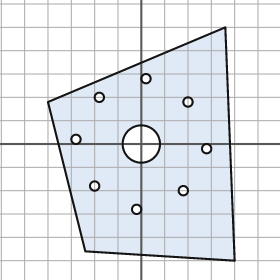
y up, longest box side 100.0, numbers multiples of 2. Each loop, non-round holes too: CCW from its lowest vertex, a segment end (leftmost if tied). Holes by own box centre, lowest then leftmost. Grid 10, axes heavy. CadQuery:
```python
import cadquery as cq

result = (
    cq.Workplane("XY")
    .moveTo(40.0, -50.0)
    .lineTo(36.0, 50.0)
    .lineTo(-40.0, 18.0)
    .lineTo(-24.0, -46.0)
    .close()
    .moveTo(-2.0, -28.0)
    .circle(2.0)
    .moveTo(18.0, -20.0)
    .circle(2.0)
    .moveTo(-20.0, -18.0)
    .circle(2.0)
    .moveTo(28.0, -2.0)
    .circle(2.0)
    .moveTo(0.0, 0.0)
    .circle(8.0)
    .moveTo(-28.0, 2.0)
    .circle(2.0)
    .moveTo(20.0, 18.0)
    .circle(2.0)
    .moveTo(-18.0, 20.0)
    .circle(2.0)
    .moveTo(2.0, 28.0)
    .circle(2.0)
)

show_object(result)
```